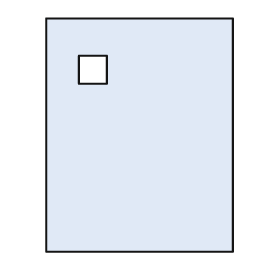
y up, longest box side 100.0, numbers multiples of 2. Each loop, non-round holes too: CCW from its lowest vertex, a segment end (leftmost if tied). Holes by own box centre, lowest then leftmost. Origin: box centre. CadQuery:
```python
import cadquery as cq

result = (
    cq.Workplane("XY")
    .moveTo(-40.0, -50.0)
    .lineTo(40.0, -50.0)
    .lineTo(40.0, 50.0)
    .lineTo(-40.0, 50.0)
    .close()
    .moveTo(-26.0, 22.0)
    .lineTo(-14.0, 22.0)
    .lineTo(-14.0, 34.0)
    .lineTo(-26.0, 34.0)
    .close()
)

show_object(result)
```